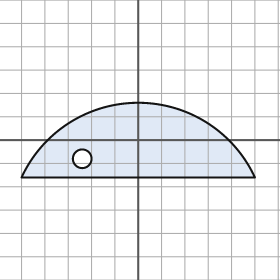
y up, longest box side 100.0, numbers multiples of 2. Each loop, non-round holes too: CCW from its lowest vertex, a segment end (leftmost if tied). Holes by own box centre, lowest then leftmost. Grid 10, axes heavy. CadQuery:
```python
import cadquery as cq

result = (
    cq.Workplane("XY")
    .moveTo(-50.0, -16.0)
    .lineTo(50.0, -16.0)
    .threePointArc((0.0, 16.0), (-50.0, -16.0))
    .close()
    .moveTo(-24.0, -8.0)
    .circle(4.0)
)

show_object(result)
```